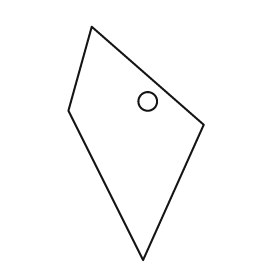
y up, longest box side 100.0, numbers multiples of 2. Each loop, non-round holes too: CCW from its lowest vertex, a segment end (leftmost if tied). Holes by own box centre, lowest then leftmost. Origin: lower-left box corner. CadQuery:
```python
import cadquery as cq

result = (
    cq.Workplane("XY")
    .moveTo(32.0, 0.0)
    .lineTo(58.0, 58.0)
    .lineTo(10.0, 100.0)
    .lineTo(0.0, 64.0)
    .close()
    .moveTo(34.0, 68.0)
    .circle(4.0)
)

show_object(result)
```